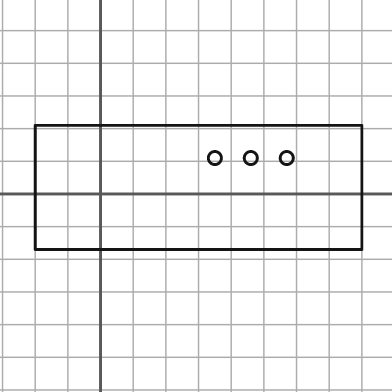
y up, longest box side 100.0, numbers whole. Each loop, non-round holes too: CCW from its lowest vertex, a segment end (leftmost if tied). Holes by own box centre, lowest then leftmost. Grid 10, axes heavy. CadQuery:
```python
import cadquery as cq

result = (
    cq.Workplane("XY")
    .moveTo(-20.0, -17.0)
    .lineTo(80.0, -17.0)
    .lineTo(80.0, 21.0)
    .lineTo(-20.0, 21.0)
    .close()
    .moveTo(35.0, 11.0)
    .circle(2.0)
    .moveTo(46.0, 11.0)
    .circle(2.0)
    .moveTo(57.0, 11.0)
    .circle(2.0)
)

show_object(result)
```